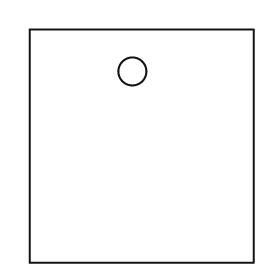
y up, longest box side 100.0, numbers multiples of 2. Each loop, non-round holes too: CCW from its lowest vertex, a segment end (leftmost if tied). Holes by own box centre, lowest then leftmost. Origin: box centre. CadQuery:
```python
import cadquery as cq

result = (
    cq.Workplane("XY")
    .moveTo(-48.0, -50.0)
    .lineTo(48.0, -50.0)
    .lineTo(48.0, 50.0)
    .lineTo(-48.0, 50.0)
    .close()
    .moveTo(-4.0, 32.0)
    .circle(6.0)
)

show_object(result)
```